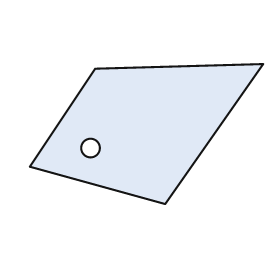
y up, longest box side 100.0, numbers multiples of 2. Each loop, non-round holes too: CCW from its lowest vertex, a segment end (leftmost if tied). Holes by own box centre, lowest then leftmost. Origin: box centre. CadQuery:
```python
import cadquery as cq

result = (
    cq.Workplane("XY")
    .moveTo(8.0, -30.0)
    .lineTo(50.0, 30.0)
    .lineTo(-22.0, 28.0)
    .lineTo(-50.0, -14.0)
    .close()
    .moveTo(-24.0, -6.0)
    .circle(4.0)
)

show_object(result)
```